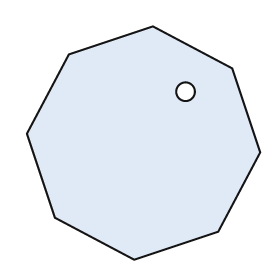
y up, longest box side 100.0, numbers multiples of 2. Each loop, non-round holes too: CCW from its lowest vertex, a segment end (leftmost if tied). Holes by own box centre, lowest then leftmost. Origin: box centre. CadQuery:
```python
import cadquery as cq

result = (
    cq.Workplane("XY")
    .moveTo(-4.0, -50.0)
    .lineTo(32.0, -38.0)
    .lineTo(50.0, -4.0)
    .lineTo(38.0, 32.0)
    .lineTo(4.0, 50.0)
    .lineTo(-32.0, 38.0)
    .lineTo(-50.0, 4.0)
    .lineTo(-38.0, -32.0)
    .close()
    .moveTo(18.0, 22.0)
    .circle(4.0)
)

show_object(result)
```